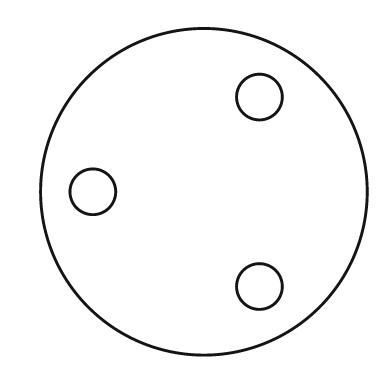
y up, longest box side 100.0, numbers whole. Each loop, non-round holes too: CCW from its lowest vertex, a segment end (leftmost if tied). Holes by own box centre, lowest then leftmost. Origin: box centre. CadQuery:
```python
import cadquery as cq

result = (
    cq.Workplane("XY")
    .moveTo(0.0, 0.0)
    .circle(50.0)
    .moveTo(17.0, -29.0)
    .circle(7.0)
    .moveTo(-34.0, 0.0)
    .circle(7.0)
    .moveTo(17.0, 29.0)
    .circle(7.0)
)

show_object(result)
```